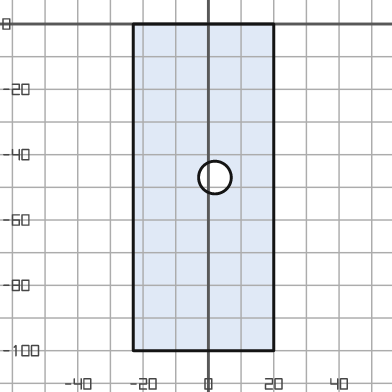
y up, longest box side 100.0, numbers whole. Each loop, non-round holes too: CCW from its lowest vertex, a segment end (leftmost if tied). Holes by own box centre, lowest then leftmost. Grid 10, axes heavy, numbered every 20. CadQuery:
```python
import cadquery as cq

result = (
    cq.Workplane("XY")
    .moveTo(-23.0, -100.0)
    .lineTo(20.0, -100.0)
    .lineTo(20.0, 0.0)
    .lineTo(-23.0, 0.0)
    .close()
    .moveTo(2.0, -47.0)
    .circle(5.0)
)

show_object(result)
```